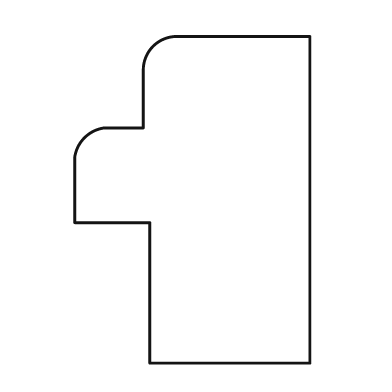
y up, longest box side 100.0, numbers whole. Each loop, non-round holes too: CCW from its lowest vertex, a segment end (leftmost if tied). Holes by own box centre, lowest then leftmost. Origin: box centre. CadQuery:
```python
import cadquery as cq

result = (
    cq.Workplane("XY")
    .moveTo(-13.0, -50.0)
    .lineTo(36.0, -50.0)
    .lineTo(36.0, 50.0)
    .lineTo(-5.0, 50.0)
    .threePointArc((-12.0, 47.0), (-15.0, 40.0))
    .lineTo(-15.0, 22.0)
    .lineTo(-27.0, 22.0)
    .threePointArc((-33.0, 19.0), (-36.0, 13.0))
    .lineTo(-36.0, -7.0)
    .lineTo(-13.0, -7.0)
    .close()
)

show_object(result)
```